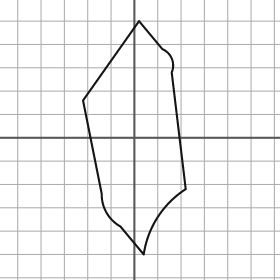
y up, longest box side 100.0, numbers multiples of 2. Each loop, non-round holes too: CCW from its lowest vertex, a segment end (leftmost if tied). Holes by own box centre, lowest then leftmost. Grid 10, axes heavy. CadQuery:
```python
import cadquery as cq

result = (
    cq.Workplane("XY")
    .moveTo(4.0, -50.0)
    .threePointArc((10.0, -34.0), (22.0, -22.0))
    .lineTo(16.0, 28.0)
    .threePointArc((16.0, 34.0), (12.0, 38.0))
    .lineTo(2.0, 50.0)
    .lineTo(-22.0, 16.0)
    .lineTo(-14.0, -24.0)
    .threePointArc((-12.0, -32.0), (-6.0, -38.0))
    .close()
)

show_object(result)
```